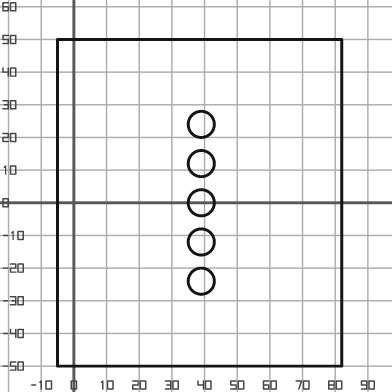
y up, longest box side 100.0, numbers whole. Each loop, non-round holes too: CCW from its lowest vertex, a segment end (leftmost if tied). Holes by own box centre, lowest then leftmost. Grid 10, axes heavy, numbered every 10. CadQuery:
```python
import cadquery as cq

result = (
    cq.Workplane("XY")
    .moveTo(-5.0, -50.0)
    .lineTo(82.0, -50.0)
    .lineTo(82.0, 50.0)
    .lineTo(-5.0, 50.0)
    .close()
    .moveTo(39.0, -24.0)
    .circle(4.0)
    .moveTo(39.0, -12.0)
    .circle(4.0)
    .moveTo(39.0, 0.0)
    .circle(4.0)
    .moveTo(39.0, 12.0)
    .circle(4.0)
    .moveTo(39.0, 24.0)
    .circle(4.0)
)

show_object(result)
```